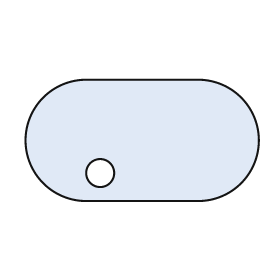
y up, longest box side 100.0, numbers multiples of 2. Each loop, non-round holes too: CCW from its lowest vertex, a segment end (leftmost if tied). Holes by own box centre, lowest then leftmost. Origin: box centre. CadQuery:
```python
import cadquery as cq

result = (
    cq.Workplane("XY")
    .moveTo(-24.0, -26.0)
    .lineTo(24.0, -26.0)
    .threePointArc((50.0, 0.0), (24.0, 26.0))
    .lineTo(-24.0, 26.0)
    .threePointArc((-50.0, 0.0), (-24.0, -26.0))
    .close()
    .moveTo(-18.0, -14.0)
    .circle(6.0)
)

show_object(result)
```